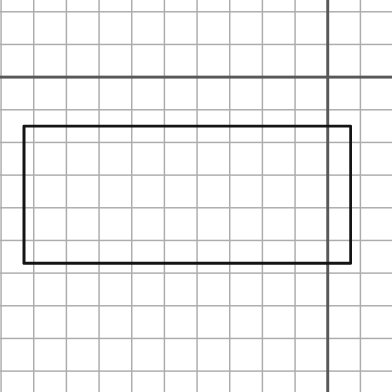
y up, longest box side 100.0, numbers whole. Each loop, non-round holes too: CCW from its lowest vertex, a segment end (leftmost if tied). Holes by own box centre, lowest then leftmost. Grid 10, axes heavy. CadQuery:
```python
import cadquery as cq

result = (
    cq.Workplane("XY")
    .moveTo(-93.0, -57.0)
    .lineTo(7.0, -57.0)
    .lineTo(7.0, -15.0)
    .lineTo(-93.0, -15.0)
    .close()
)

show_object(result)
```